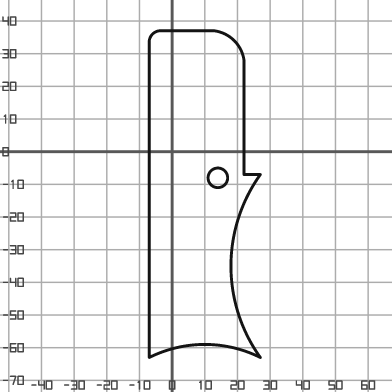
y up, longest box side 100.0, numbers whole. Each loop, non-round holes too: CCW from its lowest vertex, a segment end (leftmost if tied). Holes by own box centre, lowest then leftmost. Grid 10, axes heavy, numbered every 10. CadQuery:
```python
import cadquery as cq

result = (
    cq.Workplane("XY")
    .moveTo(-7.0, -63.0)
    .threePointArc((10.0, -59.0), (27.0, -63.0))
    .threePointArc((18.0, -35.0), (27.0, -7.0))
    .lineTo(22.0, -7.0)
    .lineTo(22.0, 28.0)
    .threePointArc((19.0, 34.0), (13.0, 37.0))
    .lineTo(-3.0, 37.0)
    .threePointArc((-6.0, 36.0), (-7.0, 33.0))
    .close()
    .moveTo(14.0, -8.0)
    .circle(3.0)
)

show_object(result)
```